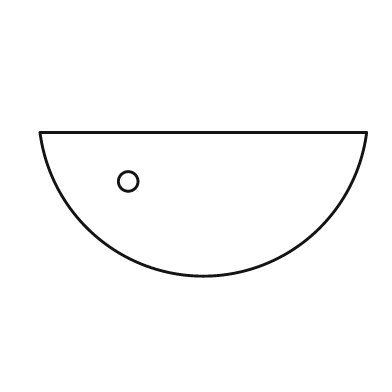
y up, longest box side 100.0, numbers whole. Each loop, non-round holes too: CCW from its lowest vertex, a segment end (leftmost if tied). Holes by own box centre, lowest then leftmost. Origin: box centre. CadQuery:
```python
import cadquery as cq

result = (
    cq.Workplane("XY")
    .moveTo(-50.0, 22.0)
    .threePointArc((0.0, -22.0), (50.0, 22.0))
    .close()
    .moveTo(-23.0, 7.0)
    .circle(3.0)
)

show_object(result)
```